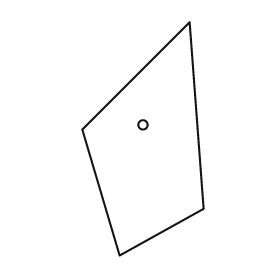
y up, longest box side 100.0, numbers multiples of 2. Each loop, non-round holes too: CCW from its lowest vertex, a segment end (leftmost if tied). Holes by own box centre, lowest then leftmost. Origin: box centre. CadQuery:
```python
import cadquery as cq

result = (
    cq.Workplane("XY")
    .moveTo(-10.0, -50.0)
    .lineTo(26.0, -30.0)
    .lineTo(20.0, 50.0)
    .lineTo(-26.0, 4.0)
    .close()
    .moveTo(0.0, 6.0)
    .circle(2.0)
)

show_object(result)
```